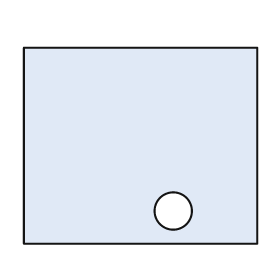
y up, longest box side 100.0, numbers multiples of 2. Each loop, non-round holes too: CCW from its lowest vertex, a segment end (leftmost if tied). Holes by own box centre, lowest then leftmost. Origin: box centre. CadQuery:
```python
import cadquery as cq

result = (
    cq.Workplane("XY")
    .moveTo(-50.0, -42.0)
    .lineTo(50.0, -42.0)
    .lineTo(50.0, 42.0)
    .lineTo(-50.0, 42.0)
    .close()
    .moveTo(14.0, -28.0)
    .circle(8.0)
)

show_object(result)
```